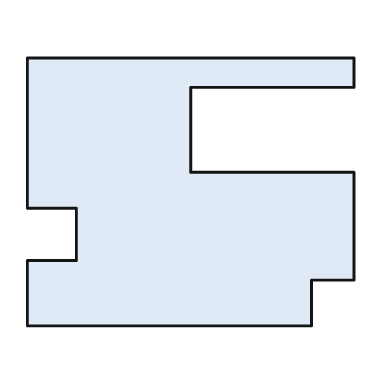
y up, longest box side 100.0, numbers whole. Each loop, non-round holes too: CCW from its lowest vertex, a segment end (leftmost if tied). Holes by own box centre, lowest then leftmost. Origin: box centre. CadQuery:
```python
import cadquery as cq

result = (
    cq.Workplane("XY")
    .moveTo(-50.0, -41.0)
    .lineTo(37.0, -41.0)
    .lineTo(37.0, -27.0)
    .lineTo(50.0, -27.0)
    .lineTo(50.0, 6.0)
    .lineTo(0.0, 6.0)
    .lineTo(0.0, 32.0)
    .lineTo(50.0, 32.0)
    .lineTo(50.0, 41.0)
    .lineTo(-50.0, 41.0)
    .lineTo(-50.0, -5.0)
    .lineTo(-35.0, -5.0)
    .lineTo(-35.0, -21.0)
    .lineTo(-50.0, -21.0)
    .close()
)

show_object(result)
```